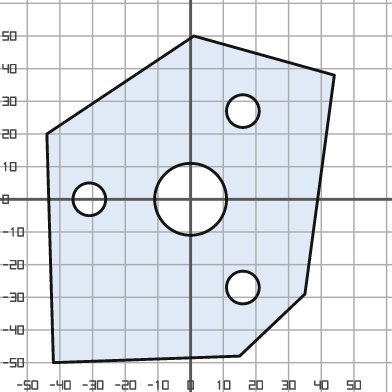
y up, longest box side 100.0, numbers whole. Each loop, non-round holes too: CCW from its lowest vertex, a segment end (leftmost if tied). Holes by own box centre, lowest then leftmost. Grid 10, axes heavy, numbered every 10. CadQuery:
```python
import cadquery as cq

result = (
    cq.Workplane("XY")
    .moveTo(-42.0, -50.0)
    .lineTo(15.0, -48.0)
    .lineTo(35.0, -29.0)
    .lineTo(44.0, 38.0)
    .lineTo(1.0, 50.0)
    .lineTo(-44.0, 20.0)
    .close()
    .moveTo(16.0, -27.0)
    .circle(5.0)
    .moveTo(-31.0, 0.0)
    .circle(5.0)
    .moveTo(0.0, 0.0)
    .circle(11.0)
    .moveTo(16.0, 27.0)
    .circle(5.0)
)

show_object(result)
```